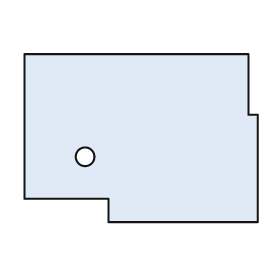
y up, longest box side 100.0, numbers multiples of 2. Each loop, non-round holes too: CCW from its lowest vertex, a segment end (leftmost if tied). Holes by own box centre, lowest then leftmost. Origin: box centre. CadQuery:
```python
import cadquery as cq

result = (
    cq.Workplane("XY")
    .moveTo(-14.0, -36.0)
    .lineTo(50.0, -36.0)
    .lineTo(50.0, 10.0)
    .lineTo(46.0, 10.0)
    .lineTo(46.0, 36.0)
    .lineTo(-50.0, 36.0)
    .lineTo(-50.0, -26.0)
    .lineTo(-14.0, -26.0)
    .close()
    .moveTo(-24.0, -8.0)
    .circle(4.0)
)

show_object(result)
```